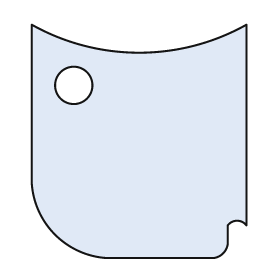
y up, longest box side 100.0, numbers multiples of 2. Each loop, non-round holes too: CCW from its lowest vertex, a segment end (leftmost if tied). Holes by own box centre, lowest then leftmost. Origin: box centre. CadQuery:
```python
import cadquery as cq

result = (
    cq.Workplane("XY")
    .moveTo(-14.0, -50.0)
    .lineTo(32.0, -50.0)
    .threePointArc((36.0, -48.0), (38.0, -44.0))
    .lineTo(38.0, -36.0)
    .threePointArc((42.0, -34.0), (46.0, -36.0))
    .lineTo(46.0, 50.0)
    .threePointArc((0.0, 38.0), (-46.0, 50.0))
    .lineTo(-46.0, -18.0)
    .threePointArc((-36.0, -40.0), (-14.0, -50.0))
    .close()
    .moveTo(-28.0, 24.0)
    .circle(8.0)
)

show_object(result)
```